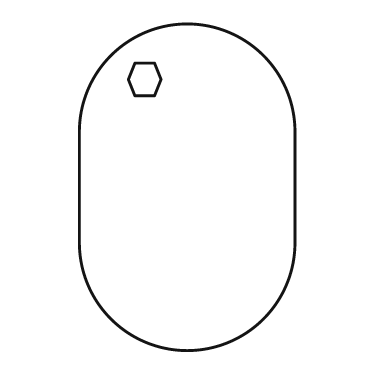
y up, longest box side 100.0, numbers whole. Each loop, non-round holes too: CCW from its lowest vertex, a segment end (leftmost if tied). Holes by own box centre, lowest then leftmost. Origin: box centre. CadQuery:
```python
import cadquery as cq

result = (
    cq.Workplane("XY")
    .moveTo(-33.0, -17.0)
    .threePointArc((0.0, -50.0), (33.0, -17.0))
    .lineTo(33.0, 17.0)
    .threePointArc((0.0, 50.0), (-33.0, 17.0))
    .close()
    .moveTo(-16.0, 28.0)
    .lineTo(-10.0, 28.0)
    .lineTo(-8.0, 33.0)
    .lineTo(-10.0, 38.0)
    .lineTo(-16.0, 38.0)
    .lineTo(-18.0, 33.0)
    .close()
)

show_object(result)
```